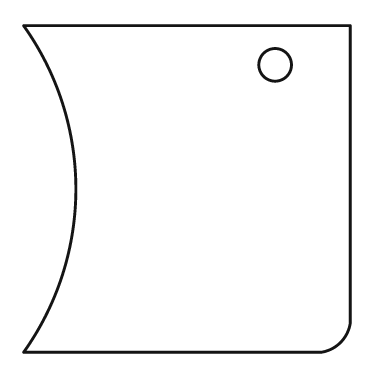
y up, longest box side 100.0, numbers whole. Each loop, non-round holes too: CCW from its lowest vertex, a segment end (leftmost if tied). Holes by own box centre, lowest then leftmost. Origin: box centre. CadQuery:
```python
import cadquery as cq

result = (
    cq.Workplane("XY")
    .moveTo(-50.0, -50.0)
    .lineTo(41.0, -50.0)
    .threePointArc((47.0, -47.0), (50.0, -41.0))
    .lineTo(50.0, 50.0)
    .lineTo(-50.0, 50.0)
    .threePointArc((-34.0, 0.0), (-50.0, -50.0))
    .close()
    .moveTo(27.0, 38.0)
    .circle(5.0)
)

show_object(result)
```